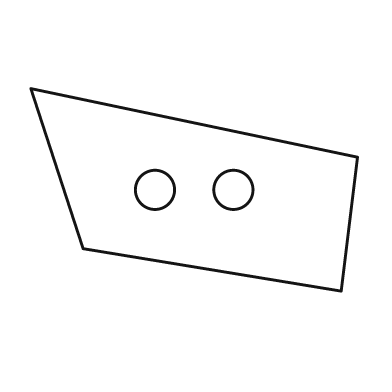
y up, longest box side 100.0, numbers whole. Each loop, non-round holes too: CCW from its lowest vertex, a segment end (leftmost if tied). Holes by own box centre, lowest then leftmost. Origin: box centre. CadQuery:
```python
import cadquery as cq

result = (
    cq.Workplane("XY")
    .moveTo(45.0, -31.0)
    .lineTo(50.0, 10.0)
    .lineTo(-50.0, 31.0)
    .lineTo(-34.0, -18.0)
    .close()
    .moveTo(-12.0, 0.0)
    .circle(6.0)
    .moveTo(12.0, 0.0)
    .circle(6.0)
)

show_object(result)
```